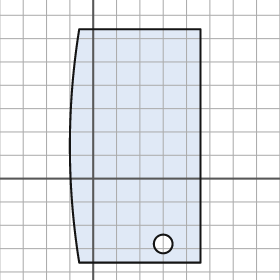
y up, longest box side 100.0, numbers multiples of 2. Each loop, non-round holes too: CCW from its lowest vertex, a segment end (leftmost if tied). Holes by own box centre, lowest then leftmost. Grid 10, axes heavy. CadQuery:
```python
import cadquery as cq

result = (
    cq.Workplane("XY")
    .moveTo(-6.0, -36.0)
    .lineTo(46.0, -36.0)
    .lineTo(46.0, 64.0)
    .lineTo(-6.0, 64.0)
    .threePointArc((-10.0, 14.0), (-6.0, -36.0))
    .close()
    .moveTo(30.0, -28.0)
    .circle(4.0)
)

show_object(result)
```